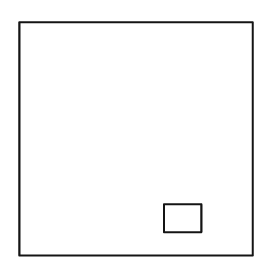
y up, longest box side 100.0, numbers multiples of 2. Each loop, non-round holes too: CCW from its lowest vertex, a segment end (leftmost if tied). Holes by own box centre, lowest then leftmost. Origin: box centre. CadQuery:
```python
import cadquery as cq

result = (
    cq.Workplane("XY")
    .moveTo(-50.0, -50.0)
    .lineTo(50.0, -50.0)
    .lineTo(50.0, 50.0)
    .lineTo(-50.0, 50.0)
    .close()
    .moveTo(12.0, -40.0)
    .lineTo(28.0, -40.0)
    .lineTo(28.0, -28.0)
    .lineTo(12.0, -28.0)
    .close()
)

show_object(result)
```